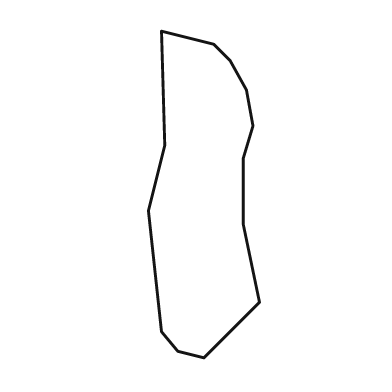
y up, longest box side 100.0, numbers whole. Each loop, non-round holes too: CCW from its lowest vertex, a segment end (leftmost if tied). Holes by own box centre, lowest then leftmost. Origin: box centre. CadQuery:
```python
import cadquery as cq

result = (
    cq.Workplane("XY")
    .moveTo(0.0, -50.0)
    .lineTo(17.0, -33.0)
    .lineTo(12.0, -9.0)
    .lineTo(12.0, 11.0)
    .lineTo(15.0, 21.0)
    .lineTo(13.0, 32.0)
    .lineTo(8.0, 41.0)
    .lineTo(3.0, 46.0)
    .lineTo(-13.0, 50.0)
    .lineTo(-12.0, 15.0)
    .lineTo(-17.0, -5.0)
    .lineTo(-13.0, -42.0)
    .lineTo(-8.0, -48.0)
    .close()
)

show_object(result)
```